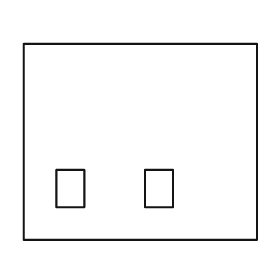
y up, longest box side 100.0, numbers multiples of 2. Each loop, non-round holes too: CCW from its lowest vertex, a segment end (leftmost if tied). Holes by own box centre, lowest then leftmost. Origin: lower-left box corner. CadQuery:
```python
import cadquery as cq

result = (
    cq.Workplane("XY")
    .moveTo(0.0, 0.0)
    .lineTo(100.0, 0.0)
    .lineTo(100.0, 84.0)
    .lineTo(0.0, 84.0)
    .close()
    .moveTo(14.0, 14.0)
    .lineTo(26.0, 14.0)
    .lineTo(26.0, 30.0)
    .lineTo(14.0, 30.0)
    .close()
    .moveTo(52.0, 14.0)
    .lineTo(64.0, 14.0)
    .lineTo(64.0, 30.0)
    .lineTo(52.0, 30.0)
    .close()
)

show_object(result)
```